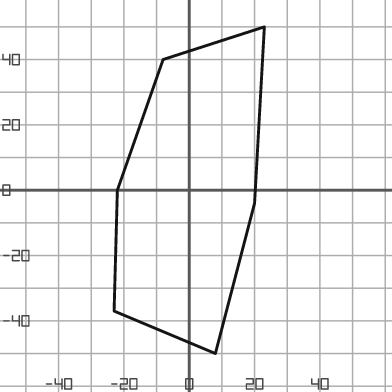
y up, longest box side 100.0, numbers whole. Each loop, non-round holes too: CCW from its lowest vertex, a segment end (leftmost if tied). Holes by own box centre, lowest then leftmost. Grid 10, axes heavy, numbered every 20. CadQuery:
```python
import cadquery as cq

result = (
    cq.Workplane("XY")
    .moveTo(8.0, -50.0)
    .lineTo(20.0, -4.0)
    .lineTo(23.0, 50.0)
    .lineTo(-8.0, 40.0)
    .lineTo(-22.0, 0.0)
    .lineTo(-23.0, -37.0)
    .close()
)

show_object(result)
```